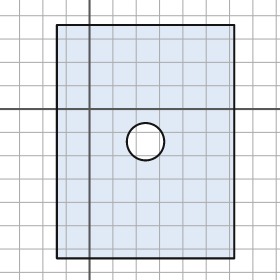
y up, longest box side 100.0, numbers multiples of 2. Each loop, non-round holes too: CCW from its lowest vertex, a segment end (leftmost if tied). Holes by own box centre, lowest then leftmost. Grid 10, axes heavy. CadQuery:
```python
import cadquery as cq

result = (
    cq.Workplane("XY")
    .moveTo(-14.0, -64.0)
    .lineTo(62.0, -64.0)
    .lineTo(62.0, 36.0)
    .lineTo(-14.0, 36.0)
    .close()
    .moveTo(24.0, -14.0)
    .circle(8.0)
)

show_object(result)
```